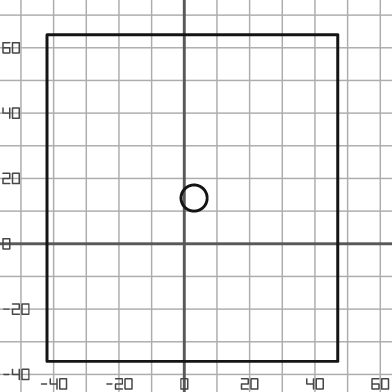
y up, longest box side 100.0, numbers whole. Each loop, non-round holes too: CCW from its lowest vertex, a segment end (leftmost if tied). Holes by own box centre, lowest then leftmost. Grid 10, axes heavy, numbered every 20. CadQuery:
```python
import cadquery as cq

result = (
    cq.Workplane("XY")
    .moveTo(-42.0, -36.0)
    .lineTo(47.0, -36.0)
    .lineTo(47.0, 64.0)
    .lineTo(-42.0, 64.0)
    .close()
    .moveTo(3.0, 14.0)
    .circle(4.0)
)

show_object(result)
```